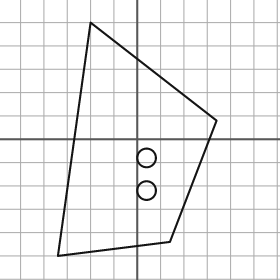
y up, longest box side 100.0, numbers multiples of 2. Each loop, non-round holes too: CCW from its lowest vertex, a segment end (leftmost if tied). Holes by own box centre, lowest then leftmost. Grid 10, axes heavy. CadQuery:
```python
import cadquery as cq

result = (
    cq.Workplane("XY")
    .moveTo(-34.0, -50.0)
    .lineTo(14.0, -44.0)
    .lineTo(34.0, 8.0)
    .lineTo(-20.0, 50.0)
    .close()
    .moveTo(4.0, -22.0)
    .circle(4.0)
    .moveTo(4.0, -8.0)
    .circle(4.0)
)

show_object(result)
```